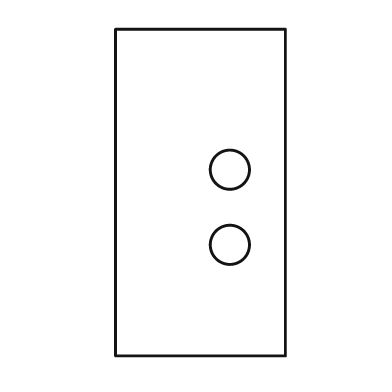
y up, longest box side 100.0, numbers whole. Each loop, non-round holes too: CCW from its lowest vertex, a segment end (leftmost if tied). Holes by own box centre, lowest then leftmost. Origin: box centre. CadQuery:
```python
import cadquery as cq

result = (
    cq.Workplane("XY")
    .moveTo(-26.0, -50.0)
    .lineTo(26.0, -50.0)
    .lineTo(26.0, 50.0)
    .lineTo(-26.0, 50.0)
    .close()
    .moveTo(9.0, -16.0)
    .circle(6.0)
    .moveTo(9.0, 7.0)
    .circle(6.0)
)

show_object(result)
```